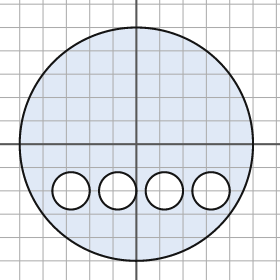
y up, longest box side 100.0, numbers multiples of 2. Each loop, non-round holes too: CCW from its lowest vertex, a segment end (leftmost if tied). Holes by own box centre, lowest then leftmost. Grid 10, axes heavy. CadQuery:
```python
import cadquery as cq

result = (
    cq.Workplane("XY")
    .moveTo(0.0, 0.0)
    .circle(50.0)
    .moveTo(-28.0, -20.0)
    .circle(8.0)
    .moveTo(-8.0, -20.0)
    .circle(8.0)
    .moveTo(12.0, -20.0)
    .circle(8.0)
    .moveTo(32.0, -20.0)
    .circle(8.0)
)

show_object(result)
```